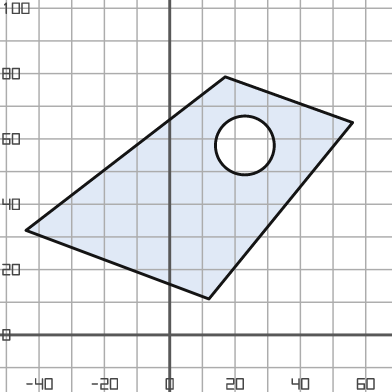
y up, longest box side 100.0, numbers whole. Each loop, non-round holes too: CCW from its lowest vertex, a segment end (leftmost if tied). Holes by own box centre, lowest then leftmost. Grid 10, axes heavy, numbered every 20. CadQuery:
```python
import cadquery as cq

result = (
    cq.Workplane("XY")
    .moveTo(12.0, 11.0)
    .lineTo(56.0, 65.0)
    .lineTo(17.0, 79.0)
    .lineTo(-44.0, 32.0)
    .close()
    .moveTo(23.0, 58.0)
    .circle(9.0)
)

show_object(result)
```